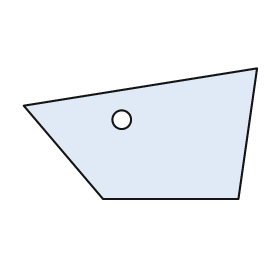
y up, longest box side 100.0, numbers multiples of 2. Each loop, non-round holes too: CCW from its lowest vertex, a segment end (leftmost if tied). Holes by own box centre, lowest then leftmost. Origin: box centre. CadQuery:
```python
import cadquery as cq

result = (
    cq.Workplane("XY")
    .moveTo(-16.0, -28.0)
    .lineTo(42.0, -28.0)
    .lineTo(50.0, 28.0)
    .lineTo(-50.0, 12.0)
    .close()
    .moveTo(-8.0, 6.0)
    .circle(4.0)
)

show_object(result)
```